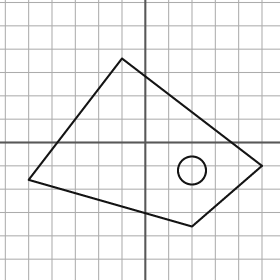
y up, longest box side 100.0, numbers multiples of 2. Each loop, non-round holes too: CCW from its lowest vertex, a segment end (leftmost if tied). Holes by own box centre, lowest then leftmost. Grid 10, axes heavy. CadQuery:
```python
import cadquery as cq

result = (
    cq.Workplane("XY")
    .moveTo(20.0, -36.0)
    .lineTo(50.0, -10.0)
    .lineTo(-10.0, 36.0)
    .lineTo(-50.0, -16.0)
    .close()
    .moveTo(20.0, -12.0)
    .circle(6.0)
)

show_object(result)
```